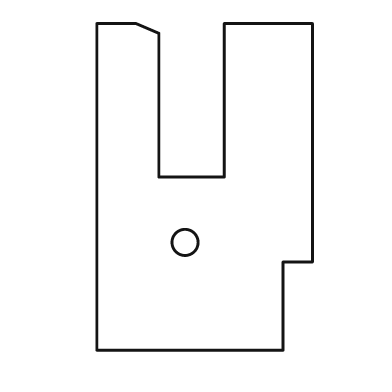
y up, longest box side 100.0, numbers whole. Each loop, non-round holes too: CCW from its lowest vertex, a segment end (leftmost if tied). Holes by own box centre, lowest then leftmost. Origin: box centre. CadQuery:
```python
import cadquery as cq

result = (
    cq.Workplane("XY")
    .moveTo(-33.0, -50.0)
    .lineTo(24.0, -50.0)
    .lineTo(24.0, -23.0)
    .lineTo(33.0, -23.0)
    .lineTo(33.0, 50.0)
    .lineTo(6.0, 50.0)
    .lineTo(6.0, 3.0)
    .lineTo(-14.0, 3.0)
    .lineTo(-14.0, 47.0)
    .lineTo(-21.0, 50.0)
    .lineTo(-33.0, 50.0)
    .close()
    .moveTo(-6.0, -17.0)
    .circle(4.0)
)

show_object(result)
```